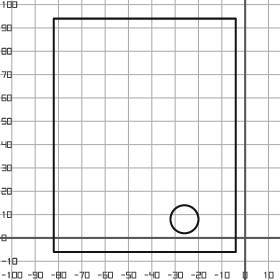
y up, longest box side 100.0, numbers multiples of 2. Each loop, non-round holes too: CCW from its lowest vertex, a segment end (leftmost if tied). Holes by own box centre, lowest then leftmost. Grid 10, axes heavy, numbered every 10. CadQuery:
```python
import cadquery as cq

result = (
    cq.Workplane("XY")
    .moveTo(-82.0, -6.0)
    .lineTo(-4.0, -6.0)
    .lineTo(-4.0, 94.0)
    .lineTo(-82.0, 94.0)
    .close()
    .moveTo(-26.0, 8.0)
    .circle(6.0)
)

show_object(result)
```